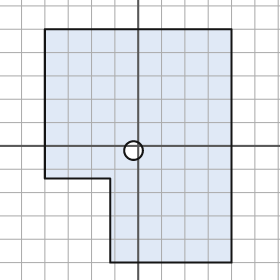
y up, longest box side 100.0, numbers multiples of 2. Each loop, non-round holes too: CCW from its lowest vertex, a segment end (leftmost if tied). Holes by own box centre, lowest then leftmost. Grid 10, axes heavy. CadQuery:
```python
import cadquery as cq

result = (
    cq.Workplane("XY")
    .moveTo(-12.0, -50.0)
    .lineTo(40.0, -50.0)
    .lineTo(40.0, 50.0)
    .lineTo(-40.0, 50.0)
    .lineTo(-40.0, -14.0)
    .lineTo(-12.0, -14.0)
    .close()
    .moveTo(-2.0, -2.0)
    .circle(4.0)
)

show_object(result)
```